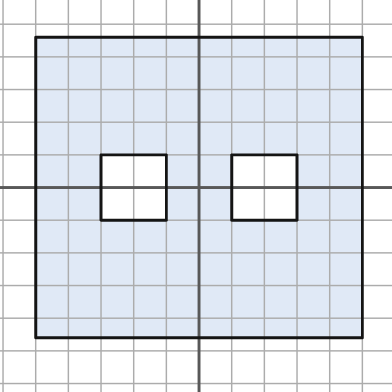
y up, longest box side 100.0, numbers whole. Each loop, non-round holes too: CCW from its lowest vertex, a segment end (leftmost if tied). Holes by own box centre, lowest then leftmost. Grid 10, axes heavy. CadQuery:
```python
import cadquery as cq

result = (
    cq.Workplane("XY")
    .moveTo(-50.0, -46.0)
    .lineTo(50.0, -46.0)
    .lineTo(50.0, 46.0)
    .lineTo(-50.0, 46.0)
    .close()
    .moveTo(-30.0, -10.0)
    .lineTo(-10.0, -10.0)
    .lineTo(-10.0, 10.0)
    .lineTo(-30.0, 10.0)
    .close()
    .moveTo(10.0, -10.0)
    .lineTo(30.0, -10.0)
    .lineTo(30.0, 10.0)
    .lineTo(10.0, 10.0)
    .close()
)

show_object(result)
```